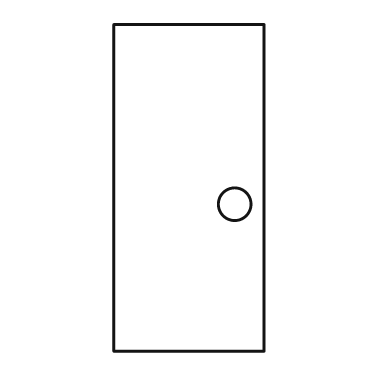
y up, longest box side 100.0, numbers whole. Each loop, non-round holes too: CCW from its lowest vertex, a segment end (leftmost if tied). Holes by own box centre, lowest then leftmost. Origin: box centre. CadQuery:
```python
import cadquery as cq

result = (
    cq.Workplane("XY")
    .moveTo(-23.0, -50.0)
    .lineTo(23.0, -50.0)
    .lineTo(23.0, 50.0)
    .lineTo(-23.0, 50.0)
    .close()
    .moveTo(14.0, -5.0)
    .circle(5.0)
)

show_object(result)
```